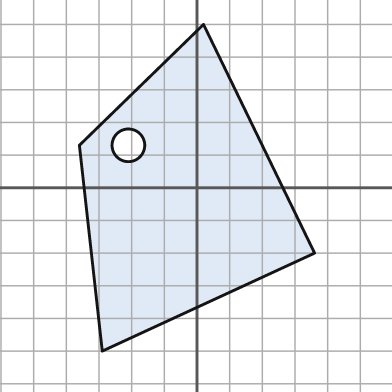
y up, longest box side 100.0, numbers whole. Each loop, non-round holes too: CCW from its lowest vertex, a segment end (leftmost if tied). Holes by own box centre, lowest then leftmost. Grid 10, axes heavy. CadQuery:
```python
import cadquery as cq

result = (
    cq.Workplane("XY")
    .moveTo(-29.0, -50.0)
    .lineTo(36.0, -20.0)
    .lineTo(2.0, 50.0)
    .lineTo(-36.0, 13.0)
    .close()
    .moveTo(-21.0, 13.0)
    .circle(5.0)
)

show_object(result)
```